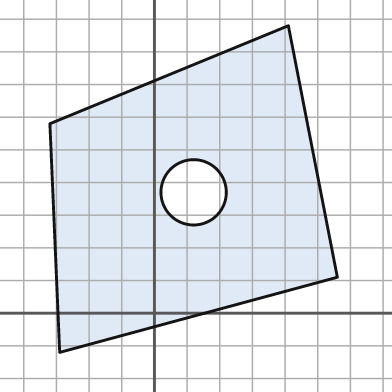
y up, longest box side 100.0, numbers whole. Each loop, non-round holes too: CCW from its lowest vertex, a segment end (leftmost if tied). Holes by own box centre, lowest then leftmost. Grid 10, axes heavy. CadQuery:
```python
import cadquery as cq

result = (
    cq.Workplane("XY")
    .moveTo(-29.0, -12.0)
    .lineTo(56.0, 11.0)
    .lineTo(41.0, 88.0)
    .lineTo(-32.0, 58.0)
    .close()
    .moveTo(12.0, 37.0)
    .circle(10.0)
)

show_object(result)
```